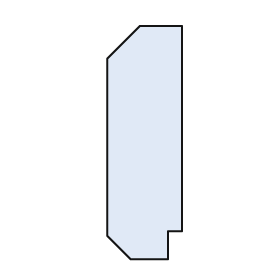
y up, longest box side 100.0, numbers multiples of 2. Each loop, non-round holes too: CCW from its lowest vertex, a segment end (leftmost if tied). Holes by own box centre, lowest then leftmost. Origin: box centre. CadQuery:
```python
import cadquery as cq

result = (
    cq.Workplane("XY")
    .moveTo(-6.0, -50.0)
    .lineTo(10.0, -50.0)
    .lineTo(10.0, -38.0)
    .lineTo(16.0, -38.0)
    .lineTo(16.0, 50.0)
    .lineTo(-2.0, 50.0)
    .lineTo(-16.0, 36.0)
    .lineTo(-16.0, -40.0)
    .close()
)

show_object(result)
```